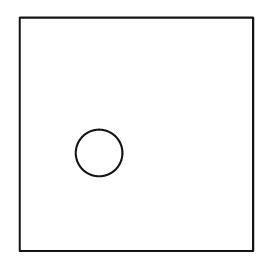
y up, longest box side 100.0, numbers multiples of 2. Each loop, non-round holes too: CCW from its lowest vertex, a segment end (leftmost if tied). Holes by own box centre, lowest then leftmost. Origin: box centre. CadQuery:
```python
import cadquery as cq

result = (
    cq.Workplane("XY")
    .moveTo(-50.0, -50.0)
    .lineTo(50.0, -50.0)
    .lineTo(50.0, 50.0)
    .lineTo(-50.0, 50.0)
    .close()
    .moveTo(-16.0, -8.0)
    .circle(10.0)
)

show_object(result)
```